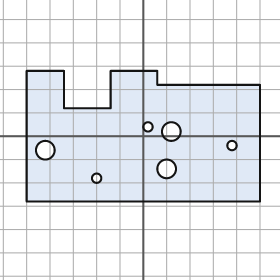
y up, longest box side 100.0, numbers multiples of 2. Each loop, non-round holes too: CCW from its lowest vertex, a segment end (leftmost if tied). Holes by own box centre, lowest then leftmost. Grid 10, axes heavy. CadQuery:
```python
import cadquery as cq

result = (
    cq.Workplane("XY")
    .moveTo(-50.0, -28.0)
    .lineTo(50.0, -28.0)
    .lineTo(50.0, 22.0)
    .lineTo(6.0, 22.0)
    .lineTo(6.0, 28.0)
    .lineTo(-14.0, 28.0)
    .lineTo(-14.0, 12.0)
    .lineTo(-34.0, 12.0)
    .lineTo(-34.0, 28.0)
    .lineTo(-50.0, 28.0)
    .close()
    .moveTo(-20.0, -18.0)
    .circle(2.0)
    .moveTo(10.0, -14.0)
    .circle(4.0)
    .moveTo(-42.0, -6.0)
    .circle(4.0)
    .moveTo(38.0, -4.0)
    .circle(2.0)
    .moveTo(12.0, 2.0)
    .circle(4.0)
    .moveTo(2.0, 4.0)
    .circle(2.0)
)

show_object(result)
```